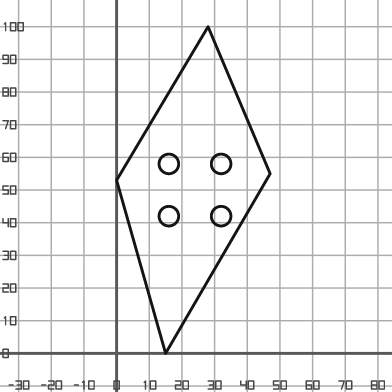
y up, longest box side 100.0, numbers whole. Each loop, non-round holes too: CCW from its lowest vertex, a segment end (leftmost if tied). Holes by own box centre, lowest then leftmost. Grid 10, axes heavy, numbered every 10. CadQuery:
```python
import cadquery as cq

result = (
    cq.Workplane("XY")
    .moveTo(15.0, 0.0)
    .lineTo(47.0, 55.0)
    .lineTo(28.0, 100.0)
    .lineTo(0.0, 53.0)
    .close()
    .moveTo(16.0, 42.0)
    .circle(3.0)
    .moveTo(32.0, 42.0)
    .circle(3.0)
    .moveTo(16.0, 58.0)
    .circle(3.0)
    .moveTo(32.0, 58.0)
    .circle(3.0)
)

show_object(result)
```